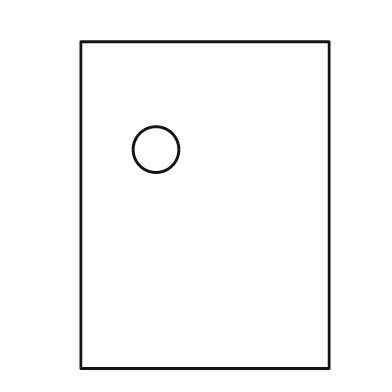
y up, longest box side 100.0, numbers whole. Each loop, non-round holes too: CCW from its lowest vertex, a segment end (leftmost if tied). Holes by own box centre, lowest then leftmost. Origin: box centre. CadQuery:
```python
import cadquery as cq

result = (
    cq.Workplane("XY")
    .moveTo(-38.0, -50.0)
    .lineTo(38.0, -50.0)
    .lineTo(38.0, 50.0)
    .lineTo(-38.0, 50.0)
    .close()
    .moveTo(-15.0, 17.0)
    .circle(7.0)
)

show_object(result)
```